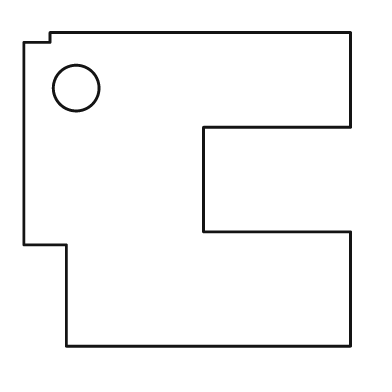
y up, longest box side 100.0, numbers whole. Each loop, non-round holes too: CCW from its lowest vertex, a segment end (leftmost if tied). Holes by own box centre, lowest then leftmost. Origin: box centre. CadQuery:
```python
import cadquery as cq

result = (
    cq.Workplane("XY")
    .moveTo(-37.0, -48.0)
    .lineTo(50.0, -48.0)
    .lineTo(50.0, -13.0)
    .lineTo(5.0, -13.0)
    .lineTo(5.0, 19.0)
    .lineTo(50.0, 19.0)
    .lineTo(50.0, 48.0)
    .lineTo(-42.0, 48.0)
    .lineTo(-42.0, 45.0)
    .lineTo(-50.0, 45.0)
    .lineTo(-50.0, -17.0)
    .lineTo(-37.0, -17.0)
    .close()
    .moveTo(-34.0, 31.0)
    .circle(7.0)
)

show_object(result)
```